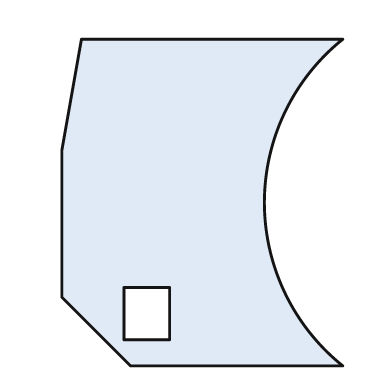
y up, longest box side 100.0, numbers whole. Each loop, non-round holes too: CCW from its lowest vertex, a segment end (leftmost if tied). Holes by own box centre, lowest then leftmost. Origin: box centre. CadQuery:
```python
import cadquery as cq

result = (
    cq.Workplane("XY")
    .moveTo(-22.0, -50.0)
    .lineTo(43.0, -50.0)
    .threePointArc((19.0, 0.0), (43.0, 50.0))
    .lineTo(-37.0, 50.0)
    .lineTo(-43.0, 16.0)
    .lineTo(-43.0, -29.0)
    .close()
    .moveTo(-24.0, -42.0)
    .lineTo(-10.0, -42.0)
    .lineTo(-10.0, -26.0)
    .lineTo(-24.0, -26.0)
    .close()
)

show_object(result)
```